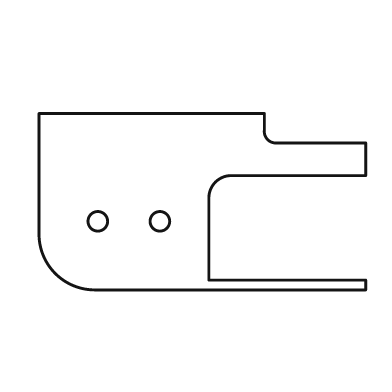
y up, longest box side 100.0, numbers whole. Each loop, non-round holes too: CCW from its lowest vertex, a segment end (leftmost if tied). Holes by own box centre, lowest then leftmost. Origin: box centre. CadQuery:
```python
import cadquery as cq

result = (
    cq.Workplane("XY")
    .moveTo(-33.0, -27.0)
    .lineTo(50.0, -27.0)
    .lineTo(50.0, -24.0)
    .lineTo(2.0, -24.0)
    .lineTo(2.0, 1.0)
    .threePointArc((4.0, 6.0), (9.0, 8.0))
    .lineTo(50.0, 8.0)
    .lineTo(50.0, 18.0)
    .lineTo(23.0, 18.0)
    .threePointArc((20.0, 19.0), (19.0, 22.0))
    .lineTo(19.0, 27.0)
    .lineTo(-50.0, 27.0)
    .lineTo(-50.0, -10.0)
    .threePointArc((-45.0, -22.0), (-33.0, -27.0))
    .close()
    .moveTo(-32.0, -6.0)
    .circle(3.0)
    .moveTo(-13.0, -6.0)
    .circle(3.0)
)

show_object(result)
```